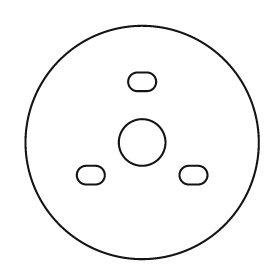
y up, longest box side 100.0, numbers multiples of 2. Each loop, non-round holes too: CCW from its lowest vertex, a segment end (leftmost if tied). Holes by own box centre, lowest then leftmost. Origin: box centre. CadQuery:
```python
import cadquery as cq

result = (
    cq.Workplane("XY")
    .moveTo(0.0, 0.0)
    .circle(50.0)
    .moveTo(-24.0, -18.0)
    .lineTo(-20.0, -18.0)
    .threePointArc((-16.0, -14.0), (-20.0, -10.0))
    .lineTo(-24.0, -10.0)
    .threePointArc((-28.0, -14.0), (-24.0, -18.0))
    .close()
    .moveTo(20.0, -18.0)
    .lineTo(24.0, -18.0)
    .threePointArc((28.0, -14.0), (24.0, -10.0))
    .lineTo(20.0, -10.0)
    .threePointArc((16.0, -14.0), (20.0, -18.0))
    .close()
    .moveTo(0.0, 0.0)
    .circle(10.0)
    .moveTo(-2.0, 22.0)
    .lineTo(2.0, 22.0)
    .threePointArc((6.0, 26.0), (2.0, 30.0))
    .lineTo(-2.0, 30.0)
    .threePointArc((-6.0, 26.0), (-2.0, 22.0))
    .close()
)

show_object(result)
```